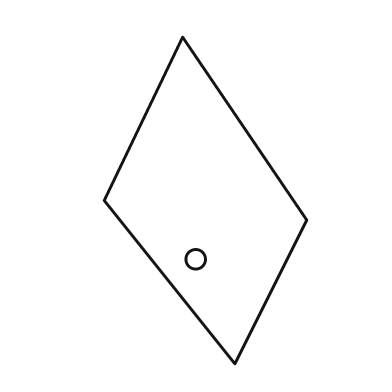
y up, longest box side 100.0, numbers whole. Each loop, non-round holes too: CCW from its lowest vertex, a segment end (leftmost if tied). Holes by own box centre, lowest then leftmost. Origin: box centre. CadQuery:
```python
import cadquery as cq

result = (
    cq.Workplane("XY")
    .moveTo(9.0, -50.0)
    .lineTo(31.0, -6.0)
    .lineTo(-7.0, 50.0)
    .lineTo(-31.0, 0.0)
    .close()
    .moveTo(-3.0, -18.0)
    .circle(3.0)
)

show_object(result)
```